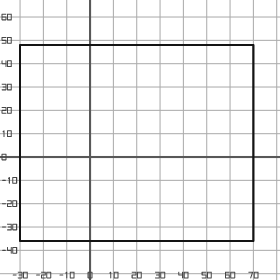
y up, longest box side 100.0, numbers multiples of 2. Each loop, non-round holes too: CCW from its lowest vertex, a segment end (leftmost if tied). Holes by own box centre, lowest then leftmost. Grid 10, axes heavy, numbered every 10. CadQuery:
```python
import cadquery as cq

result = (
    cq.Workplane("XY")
    .moveTo(-30.0, -36.0)
    .lineTo(70.0, -36.0)
    .lineTo(70.0, 48.0)
    .lineTo(-30.0, 48.0)
    .close()
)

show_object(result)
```